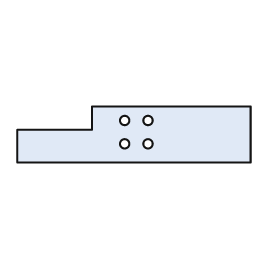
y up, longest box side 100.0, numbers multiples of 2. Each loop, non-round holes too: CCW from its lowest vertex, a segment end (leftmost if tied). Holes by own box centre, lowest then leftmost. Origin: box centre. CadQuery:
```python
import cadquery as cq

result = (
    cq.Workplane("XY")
    .moveTo(-50.0, -12.0)
    .lineTo(50.0, -12.0)
    .lineTo(50.0, 12.0)
    .lineTo(-18.0, 12.0)
    .lineTo(-18.0, 2.0)
    .lineTo(-50.0, 2.0)
    .close()
    .moveTo(-4.0, -4.0)
    .circle(2.0)
    .moveTo(6.0, -4.0)
    .circle(2.0)
    .moveTo(-4.0, 6.0)
    .circle(2.0)
    .moveTo(6.0, 6.0)
    .circle(2.0)
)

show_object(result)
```